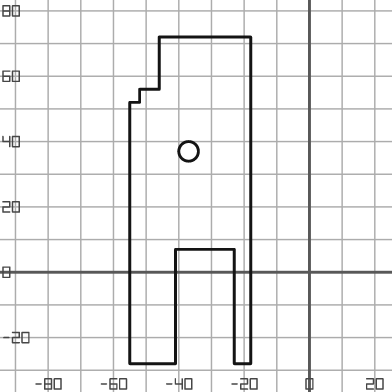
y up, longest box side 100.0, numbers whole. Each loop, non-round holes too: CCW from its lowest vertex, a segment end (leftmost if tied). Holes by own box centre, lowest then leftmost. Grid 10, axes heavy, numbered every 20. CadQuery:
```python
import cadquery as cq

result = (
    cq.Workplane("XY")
    .moveTo(-55.0, -28.0)
    .lineTo(-41.0, -28.0)
    .lineTo(-41.0, 7.0)
    .lineTo(-23.0, 7.0)
    .lineTo(-23.0, -28.0)
    .lineTo(-18.0, -28.0)
    .lineTo(-18.0, 72.0)
    .lineTo(-46.0, 72.0)
    .lineTo(-46.0, 56.0)
    .lineTo(-52.0, 56.0)
    .lineTo(-52.0, 52.0)
    .lineTo(-55.0, 52.0)
    .close()
    .moveTo(-37.0, 37.0)
    .circle(3.0)
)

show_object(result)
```